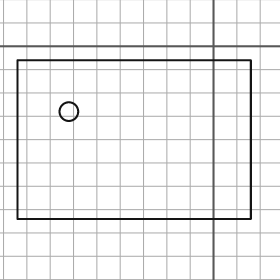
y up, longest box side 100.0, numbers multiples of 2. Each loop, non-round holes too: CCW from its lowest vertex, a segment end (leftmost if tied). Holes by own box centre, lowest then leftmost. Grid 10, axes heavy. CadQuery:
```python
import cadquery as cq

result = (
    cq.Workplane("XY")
    .moveTo(-84.0, -74.0)
    .lineTo(16.0, -74.0)
    .lineTo(16.0, -6.0)
    .lineTo(-84.0, -6.0)
    .close()
    .moveTo(-62.0, -28.0)
    .circle(4.0)
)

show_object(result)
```